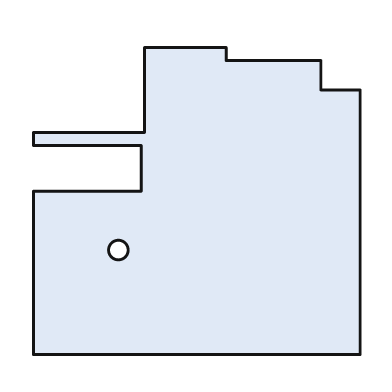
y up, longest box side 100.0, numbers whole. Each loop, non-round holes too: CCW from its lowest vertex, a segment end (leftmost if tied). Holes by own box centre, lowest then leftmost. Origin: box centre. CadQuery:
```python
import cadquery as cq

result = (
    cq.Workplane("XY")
    .moveTo(-50.0, -47.0)
    .lineTo(50.0, -47.0)
    .lineTo(50.0, 34.0)
    .lineTo(38.0, 34.0)
    .lineTo(38.0, 43.0)
    .lineTo(9.0, 43.0)
    .lineTo(9.0, 47.0)
    .lineTo(-16.0, 47.0)
    .lineTo(-16.0, 21.0)
    .lineTo(-50.0, 21.0)
    .lineTo(-50.0, 17.0)
    .lineTo(-17.0, 17.0)
    .lineTo(-17.0, 3.0)
    .lineTo(-50.0, 3.0)
    .close()
    .moveTo(-24.0, -15.0)
    .circle(3.0)
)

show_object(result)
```